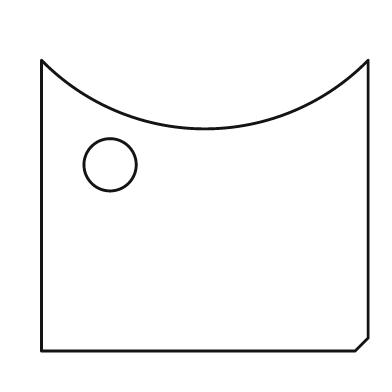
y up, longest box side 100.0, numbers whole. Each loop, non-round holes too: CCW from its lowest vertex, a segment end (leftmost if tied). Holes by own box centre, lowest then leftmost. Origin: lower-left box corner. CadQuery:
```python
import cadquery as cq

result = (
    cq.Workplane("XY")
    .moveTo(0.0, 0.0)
    .lineTo(96.0, 0.0)
    .lineTo(100.0, 4.0)
    .lineTo(100.0, 89.0)
    .threePointArc((50.0, 68.0), (0.0, 89.0))
    .close()
    .moveTo(21.0, 57.0)
    .circle(8.0)
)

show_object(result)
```